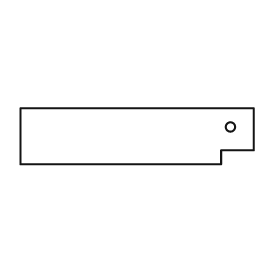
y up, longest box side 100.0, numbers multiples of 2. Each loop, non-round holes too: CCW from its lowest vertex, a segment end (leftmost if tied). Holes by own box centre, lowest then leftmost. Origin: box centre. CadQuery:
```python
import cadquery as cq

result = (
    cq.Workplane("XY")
    .moveTo(-50.0, -12.0)
    .lineTo(36.0, -12.0)
    .lineTo(36.0, -6.0)
    .lineTo(50.0, -6.0)
    .lineTo(50.0, 12.0)
    .lineTo(-50.0, 12.0)
    .close()
    .moveTo(40.0, 4.0)
    .circle(2.0)
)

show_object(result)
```